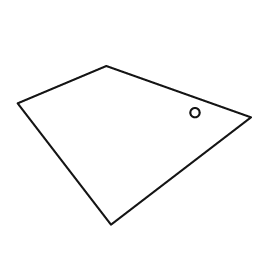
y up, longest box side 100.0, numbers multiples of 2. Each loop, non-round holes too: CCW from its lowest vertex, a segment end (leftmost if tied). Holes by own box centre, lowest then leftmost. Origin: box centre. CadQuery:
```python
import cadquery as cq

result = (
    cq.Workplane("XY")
    .moveTo(-10.0, -34.0)
    .lineTo(50.0, 12.0)
    .lineTo(-12.0, 34.0)
    .lineTo(-50.0, 18.0)
    .close()
    .moveTo(26.0, 14.0)
    .circle(2.0)
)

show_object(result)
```